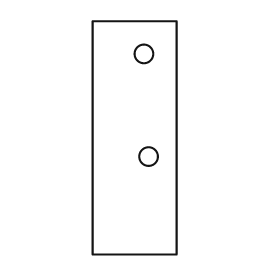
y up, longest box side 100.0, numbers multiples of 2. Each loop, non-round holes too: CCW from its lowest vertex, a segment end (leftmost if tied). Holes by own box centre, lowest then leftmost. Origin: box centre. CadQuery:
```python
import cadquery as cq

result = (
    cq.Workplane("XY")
    .moveTo(-18.0, -50.0)
    .lineTo(18.0, -50.0)
    .lineTo(18.0, 50.0)
    .lineTo(-18.0, 50.0)
    .close()
    .moveTo(6.0, -8.0)
    .circle(4.0)
    .moveTo(4.0, 36.0)
    .circle(4.0)
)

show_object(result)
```